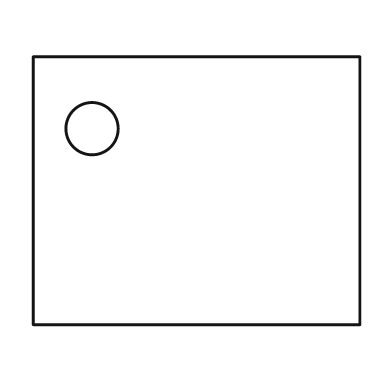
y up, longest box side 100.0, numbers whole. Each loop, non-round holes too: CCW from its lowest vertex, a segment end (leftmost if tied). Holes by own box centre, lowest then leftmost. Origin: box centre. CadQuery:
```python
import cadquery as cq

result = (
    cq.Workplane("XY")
    .moveTo(-50.0, -41.0)
    .lineTo(50.0, -41.0)
    .lineTo(50.0, 41.0)
    .lineTo(-50.0, 41.0)
    .close()
    .moveTo(-32.0, 19.0)
    .circle(8.0)
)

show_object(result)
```